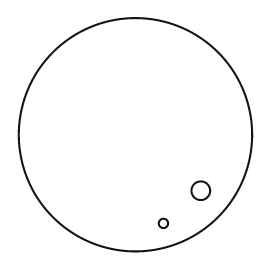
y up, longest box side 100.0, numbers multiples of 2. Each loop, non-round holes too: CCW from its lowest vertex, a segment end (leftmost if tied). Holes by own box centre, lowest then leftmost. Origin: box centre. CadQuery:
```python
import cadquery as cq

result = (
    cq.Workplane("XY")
    .moveTo(0.0, 0.0)
    .circle(50.0)
    .moveTo(12.0, -38.0)
    .circle(2.0)
    .moveTo(28.0, -24.0)
    .circle(4.0)
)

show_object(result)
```